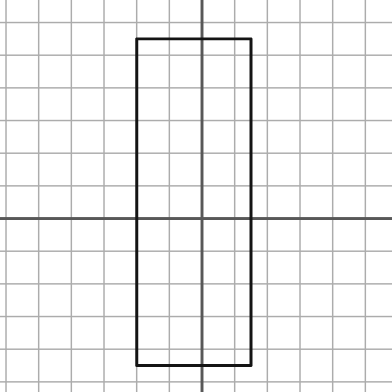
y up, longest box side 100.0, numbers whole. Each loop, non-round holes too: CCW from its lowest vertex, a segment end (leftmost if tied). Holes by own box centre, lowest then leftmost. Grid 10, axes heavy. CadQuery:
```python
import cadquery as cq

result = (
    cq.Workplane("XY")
    .moveTo(-20.0, -45.0)
    .lineTo(15.0, -45.0)
    .lineTo(15.0, 55.0)
    .lineTo(-20.0, 55.0)
    .close()
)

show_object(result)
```